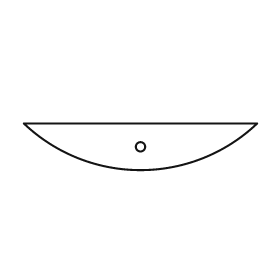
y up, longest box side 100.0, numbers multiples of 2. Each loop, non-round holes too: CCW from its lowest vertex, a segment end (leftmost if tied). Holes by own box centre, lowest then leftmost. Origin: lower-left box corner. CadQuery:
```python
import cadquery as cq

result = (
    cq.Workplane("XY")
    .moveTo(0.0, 20.0)
    .threePointArc((50.0, 0.0), (100.0, 20.0))
    .close()
    .moveTo(50.0, 10.0)
    .circle(2.0)
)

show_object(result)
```